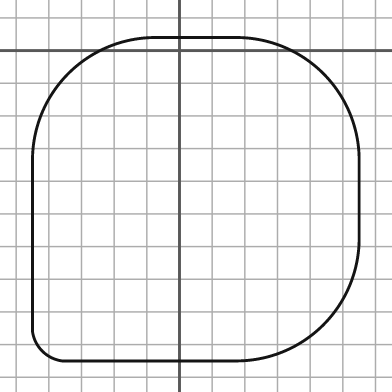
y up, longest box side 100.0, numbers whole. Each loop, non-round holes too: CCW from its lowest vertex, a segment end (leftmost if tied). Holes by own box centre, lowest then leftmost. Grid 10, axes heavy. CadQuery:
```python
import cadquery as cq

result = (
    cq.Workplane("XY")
    .moveTo(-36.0, -95.0)
    .lineTo(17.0, -95.0)
    .threePointArc((44.0, -84.0), (55.0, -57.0))
    .lineTo(55.0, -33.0)
    .threePointArc((44.0, -7.0), (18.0, 4.0))
    .lineTo(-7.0, 4.0)
    .threePointArc((-34.0, -7.0), (-45.0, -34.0))
    .lineTo(-45.0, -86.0)
    .threePointArc((-42.0, -92.0), (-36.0, -95.0))
    .close()
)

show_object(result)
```